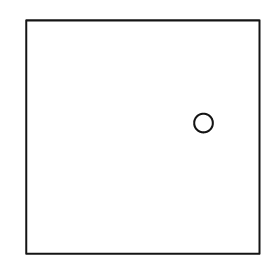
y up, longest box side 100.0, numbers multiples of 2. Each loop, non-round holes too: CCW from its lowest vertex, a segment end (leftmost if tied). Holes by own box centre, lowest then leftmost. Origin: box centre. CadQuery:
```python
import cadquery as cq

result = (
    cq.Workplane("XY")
    .moveTo(-50.0, -50.0)
    .lineTo(50.0, -50.0)
    .lineTo(50.0, 50.0)
    .lineTo(-50.0, 50.0)
    .close()
    .moveTo(26.0, 6.0)
    .circle(4.0)
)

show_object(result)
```